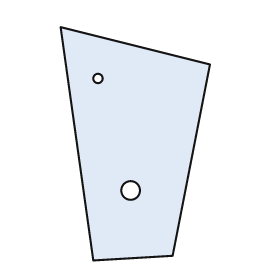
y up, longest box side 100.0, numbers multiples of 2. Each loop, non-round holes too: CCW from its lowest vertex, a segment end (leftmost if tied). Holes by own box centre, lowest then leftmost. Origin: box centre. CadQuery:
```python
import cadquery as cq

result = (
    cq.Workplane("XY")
    .moveTo(-18.0, -50.0)
    .lineTo(16.0, -48.0)
    .lineTo(32.0, 34.0)
    .lineTo(-32.0, 50.0)
    .close()
    .moveTo(-2.0, -20.0)
    .circle(4.0)
    .moveTo(-16.0, 28.0)
    .circle(2.0)
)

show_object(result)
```